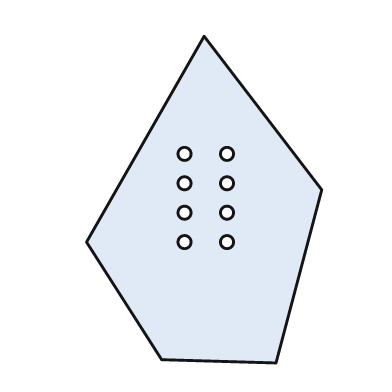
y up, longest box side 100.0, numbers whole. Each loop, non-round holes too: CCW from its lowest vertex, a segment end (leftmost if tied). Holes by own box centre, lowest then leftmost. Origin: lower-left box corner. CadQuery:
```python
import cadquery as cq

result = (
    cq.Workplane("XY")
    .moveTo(58.0, 0.0)
    .lineTo(72.0, 53.0)
    .lineTo(36.0, 100.0)
    .lineTo(0.0, 37.0)
    .lineTo(23.0, 1.0)
    .close()
    .moveTo(30.0, 37.0)
    .circle(2.0)
    .moveTo(43.0, 37.0)
    .circle(2.0)
    .moveTo(30.0, 46.0)
    .circle(2.0)
    .moveTo(43.0, 46.0)
    .circle(2.0)
    .moveTo(30.0, 55.0)
    .circle(2.0)
    .moveTo(43.0, 55.0)
    .circle(2.0)
    .moveTo(30.0, 64.0)
    .circle(2.0)
    .moveTo(43.0, 64.0)
    .circle(2.0)
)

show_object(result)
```